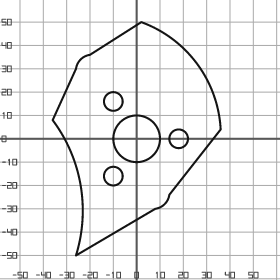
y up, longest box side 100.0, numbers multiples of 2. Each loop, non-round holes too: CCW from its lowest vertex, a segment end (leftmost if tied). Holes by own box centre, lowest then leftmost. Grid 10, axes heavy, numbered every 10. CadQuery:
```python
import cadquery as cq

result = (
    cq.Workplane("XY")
    .moveTo(-26.0, -50.0)
    .lineTo(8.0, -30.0)
    .threePointArc((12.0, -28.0), (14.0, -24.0))
    .lineTo(36.0, 4.0)
    .threePointArc((26.0, 32.0), (2.0, 50.0))
    .lineTo(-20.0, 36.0)
    .threePointArc((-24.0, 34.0), (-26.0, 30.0))
    .lineTo(-36.0, 8.0)
    .threePointArc((-24.0, -20.0), (-26.0, -50.0))
    .close()
    .moveTo(-10.0, -16.0)
    .circle(4.0)
    .moveTo(0.0, 0.0)
    .circle(10.0)
    .moveTo(18.0, 0.0)
    .circle(4.0)
    .moveTo(-10.0, 16.0)
    .circle(4.0)
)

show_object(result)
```